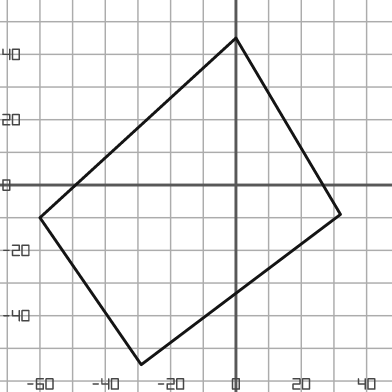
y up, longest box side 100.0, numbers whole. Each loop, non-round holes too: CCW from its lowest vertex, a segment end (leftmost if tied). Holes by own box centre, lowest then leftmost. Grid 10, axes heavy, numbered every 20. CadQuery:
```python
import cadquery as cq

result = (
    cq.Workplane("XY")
    .moveTo(-29.0, -55.0)
    .lineTo(32.0, -9.0)
    .lineTo(0.0, 45.0)
    .lineTo(-60.0, -10.0)
    .close()
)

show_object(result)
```